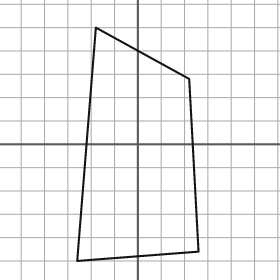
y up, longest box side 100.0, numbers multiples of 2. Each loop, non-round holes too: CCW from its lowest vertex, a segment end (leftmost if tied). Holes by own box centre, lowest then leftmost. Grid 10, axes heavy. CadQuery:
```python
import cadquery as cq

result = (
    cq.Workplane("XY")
    .moveTo(-26.0, -50.0)
    .lineTo(26.0, -46.0)
    .lineTo(22.0, 28.0)
    .lineTo(-18.0, 50.0)
    .close()
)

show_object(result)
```